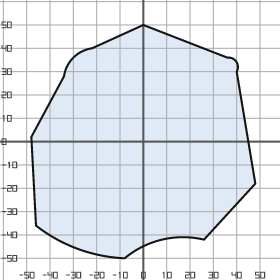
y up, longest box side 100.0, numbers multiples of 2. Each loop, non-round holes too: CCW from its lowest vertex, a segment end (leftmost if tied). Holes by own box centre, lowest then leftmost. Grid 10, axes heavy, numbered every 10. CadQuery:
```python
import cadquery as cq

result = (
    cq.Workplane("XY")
    .moveTo(-8.0, -50.0)
    .threePointArc((8.0, -42.0), (26.0, -42.0))
    .lineTo(48.0, -18.0)
    .lineTo(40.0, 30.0)
    .threePointArc((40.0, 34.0), (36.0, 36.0))
    .lineTo(0.0, 50.0)
    .lineTo(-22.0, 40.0)
    .threePointArc((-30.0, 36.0), (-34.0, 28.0))
    .lineTo(-48.0, 2.0)
    .lineTo(-46.0, -36.0)
    .threePointArc((-28.0, -46.0), (-8.0, -50.0))
    .close()
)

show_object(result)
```